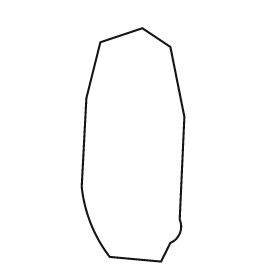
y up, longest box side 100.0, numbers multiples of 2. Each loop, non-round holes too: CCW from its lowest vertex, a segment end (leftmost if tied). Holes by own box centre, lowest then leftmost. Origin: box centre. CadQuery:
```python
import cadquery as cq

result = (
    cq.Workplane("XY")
    .moveTo(12.0, -50.0)
    .lineTo(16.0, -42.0)
    .threePointArc((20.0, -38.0), (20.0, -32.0))
    .lineTo(22.0, 12.0)
    .lineTo(16.0, 42.0)
    .lineTo(4.0, 50.0)
    .lineTo(-14.0, 44.0)
    .lineTo(-20.0, 20.0)
    .lineTo(-22.0, -18.0)
    .threePointArc((-18.0, -34.0), (-10.0, -48.0))
    .close()
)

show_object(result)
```